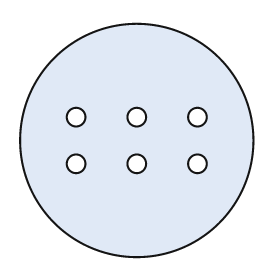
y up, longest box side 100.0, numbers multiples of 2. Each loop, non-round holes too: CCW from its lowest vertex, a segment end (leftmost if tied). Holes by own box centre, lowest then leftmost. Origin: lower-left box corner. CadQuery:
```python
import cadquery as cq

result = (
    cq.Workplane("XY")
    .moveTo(50.0, 50.0)
    .circle(50.0)
    .moveTo(24.0, 40.0)
    .circle(4.0)
    .moveTo(50.0, 40.0)
    .circle(4.0)
    .moveTo(76.0, 40.0)
    .circle(4.0)
    .moveTo(24.0, 60.0)
    .circle(4.0)
    .moveTo(50.0, 60.0)
    .circle(4.0)
    .moveTo(76.0, 60.0)
    .circle(4.0)
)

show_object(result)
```